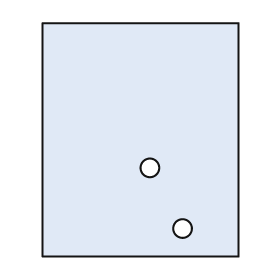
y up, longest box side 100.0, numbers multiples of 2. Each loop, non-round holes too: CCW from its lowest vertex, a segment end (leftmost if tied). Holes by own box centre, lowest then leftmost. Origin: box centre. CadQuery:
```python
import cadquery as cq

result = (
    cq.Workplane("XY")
    .moveTo(-42.0, -50.0)
    .lineTo(42.0, -50.0)
    .lineTo(42.0, 50.0)
    .lineTo(-42.0, 50.0)
    .close()
    .moveTo(18.0, -38.0)
    .circle(4.0)
    .moveTo(4.0, -12.0)
    .circle(4.0)
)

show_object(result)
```